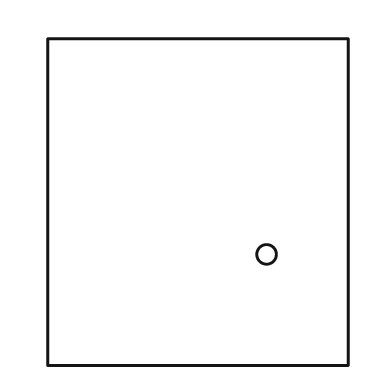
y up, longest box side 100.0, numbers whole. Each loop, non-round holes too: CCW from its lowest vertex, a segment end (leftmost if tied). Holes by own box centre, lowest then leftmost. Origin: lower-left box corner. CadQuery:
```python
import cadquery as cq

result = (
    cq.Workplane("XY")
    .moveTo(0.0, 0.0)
    .lineTo(92.0, 0.0)
    .lineTo(92.0, 100.0)
    .lineTo(0.0, 100.0)
    .close()
    .moveTo(67.0, 34.0)
    .circle(3.0)
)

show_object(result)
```